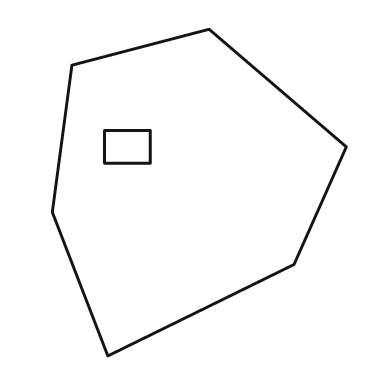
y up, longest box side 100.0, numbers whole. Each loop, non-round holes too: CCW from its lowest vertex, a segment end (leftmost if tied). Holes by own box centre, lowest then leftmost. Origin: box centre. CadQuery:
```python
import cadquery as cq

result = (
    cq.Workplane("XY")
    .moveTo(-28.0, -50.0)
    .lineTo(29.0, -22.0)
    .lineTo(45.0, 14.0)
    .lineTo(3.0, 50.0)
    .lineTo(-39.0, 39.0)
    .lineTo(-45.0, -6.0)
    .close()
    .moveTo(-29.0, 9.0)
    .lineTo(-15.0, 9.0)
    .lineTo(-15.0, 19.0)
    .lineTo(-29.0, 19.0)
    .close()
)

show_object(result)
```